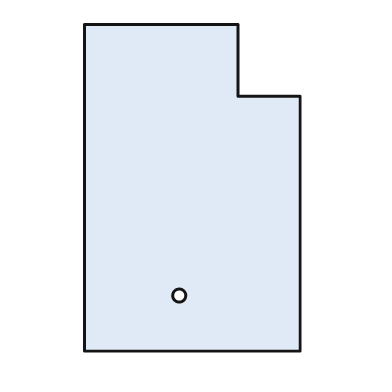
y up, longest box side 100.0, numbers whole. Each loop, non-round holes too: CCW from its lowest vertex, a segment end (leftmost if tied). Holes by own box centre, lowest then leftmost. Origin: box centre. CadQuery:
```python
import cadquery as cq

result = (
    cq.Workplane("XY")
    .moveTo(-33.0, -50.0)
    .lineTo(33.0, -50.0)
    .lineTo(33.0, 28.0)
    .lineTo(14.0, 28.0)
    .lineTo(14.0, 50.0)
    .lineTo(-33.0, 50.0)
    .close()
    .moveTo(-4.0, -33.0)
    .circle(2.0)
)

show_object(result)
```